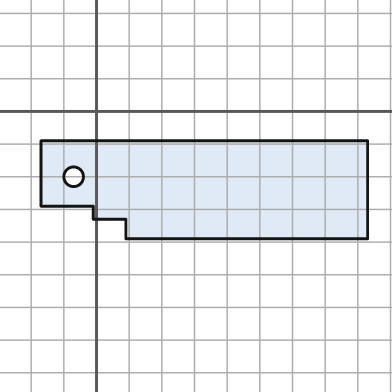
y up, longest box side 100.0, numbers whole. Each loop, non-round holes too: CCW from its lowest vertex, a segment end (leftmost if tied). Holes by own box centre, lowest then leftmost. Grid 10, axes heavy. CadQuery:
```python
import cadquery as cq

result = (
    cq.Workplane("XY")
    .moveTo(9.0, -39.0)
    .lineTo(83.0, -39.0)
    .lineTo(83.0, -9.0)
    .lineTo(-17.0, -9.0)
    .lineTo(-17.0, -29.0)
    .lineTo(-1.0, -29.0)
    .lineTo(-1.0, -33.0)
    .lineTo(9.0, -33.0)
    .close()
    .moveTo(-7.0, -20.0)
    .circle(3.0)
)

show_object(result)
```